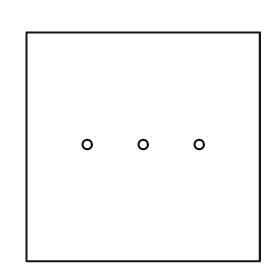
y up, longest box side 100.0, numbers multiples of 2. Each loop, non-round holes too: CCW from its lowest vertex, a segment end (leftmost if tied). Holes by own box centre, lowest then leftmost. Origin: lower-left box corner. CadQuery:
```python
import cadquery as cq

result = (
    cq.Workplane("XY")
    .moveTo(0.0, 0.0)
    .lineTo(100.0, 0.0)
    .lineTo(100.0, 98.0)
    .lineTo(0.0, 98.0)
    .close()
    .moveTo(26.0, 50.0)
    .circle(2.0)
    .moveTo(50.0, 50.0)
    .circle(2.0)
    .moveTo(74.0, 50.0)
    .circle(2.0)
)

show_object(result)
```